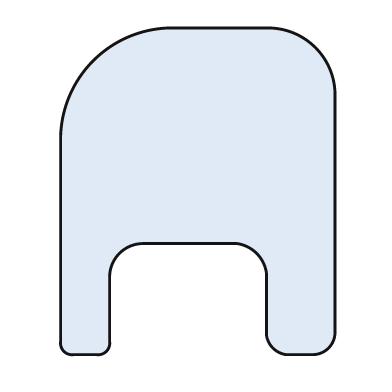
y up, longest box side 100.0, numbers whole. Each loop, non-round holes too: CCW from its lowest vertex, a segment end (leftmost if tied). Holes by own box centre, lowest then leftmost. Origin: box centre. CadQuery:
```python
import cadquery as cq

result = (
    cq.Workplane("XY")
    .moveTo(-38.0, -50.0)
    .lineTo(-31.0, -50.0)
    .threePointArc((-28.0, -49.0), (-27.0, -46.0))
    .lineTo(-27.0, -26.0)
    .threePointArc((-24.0, -19.0), (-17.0, -16.0))
    .lineTo(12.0, -16.0)
    .threePointArc((18.0, -19.0), (21.0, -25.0))
    .lineTo(21.0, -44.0)
    .threePointArc((23.0, -48.0), (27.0, -50.0))
    .lineTo(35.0, -50.0)
    .threePointArc((40.0, -48.0), (42.0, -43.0))
    .lineTo(42.0, 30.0)
    .threePointArc((36.0, 44.0), (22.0, 50.0))
    .lineTo(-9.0, 50.0)
    .threePointArc((-32.0, 40.0), (-42.0, 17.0))
    .lineTo(-42.0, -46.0)
    .threePointArc((-41.0, -49.0), (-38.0, -50.0))
    .close()
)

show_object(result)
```